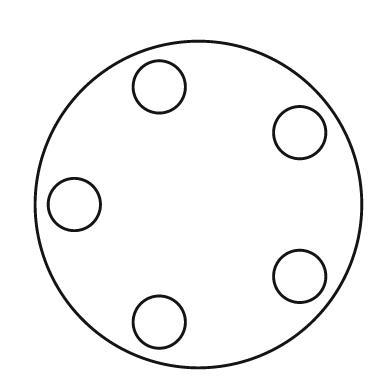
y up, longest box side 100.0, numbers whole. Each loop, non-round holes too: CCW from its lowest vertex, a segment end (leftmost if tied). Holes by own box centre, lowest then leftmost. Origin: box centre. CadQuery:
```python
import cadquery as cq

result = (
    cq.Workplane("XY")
    .moveTo(0.0, 0.0)
    .circle(50.0)
    .moveTo(-12.0, -36.0)
    .circle(8.0)
    .moveTo(31.0, -22.0)
    .circle(8.0)
    .moveTo(-38.0, 0.0)
    .circle(8.0)
    .moveTo(31.0, 22.0)
    .circle(8.0)
    .moveTo(-12.0, 36.0)
    .circle(8.0)
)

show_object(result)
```